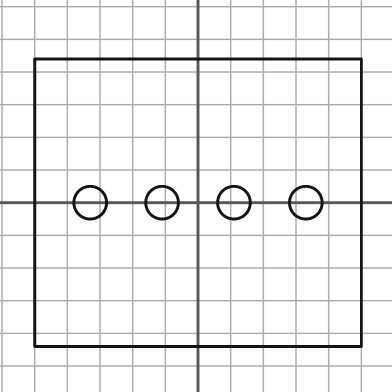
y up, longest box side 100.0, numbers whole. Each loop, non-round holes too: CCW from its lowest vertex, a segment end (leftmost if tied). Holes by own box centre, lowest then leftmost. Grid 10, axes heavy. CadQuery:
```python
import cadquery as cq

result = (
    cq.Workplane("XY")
    .moveTo(-50.0, -44.0)
    .lineTo(50.0, -44.0)
    .lineTo(50.0, 44.0)
    .lineTo(-50.0, 44.0)
    .close()
    .moveTo(-33.0, 0.0)
    .circle(5.0)
    .moveTo(-11.0, 0.0)
    .circle(5.0)
    .moveTo(11.0, 0.0)
    .circle(5.0)
    .moveTo(33.0, 0.0)
    .circle(5.0)
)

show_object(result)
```